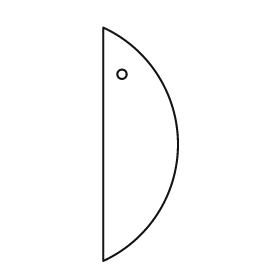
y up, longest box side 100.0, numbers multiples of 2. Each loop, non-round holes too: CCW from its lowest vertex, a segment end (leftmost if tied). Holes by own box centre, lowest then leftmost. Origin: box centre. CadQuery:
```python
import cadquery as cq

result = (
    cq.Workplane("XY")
    .moveTo(-16.0, -50.0)
    .threePointArc((16.0, 0.0), (-16.0, 50.0))
    .close()
    .moveTo(-8.0, 30.0)
    .circle(2.0)
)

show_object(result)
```